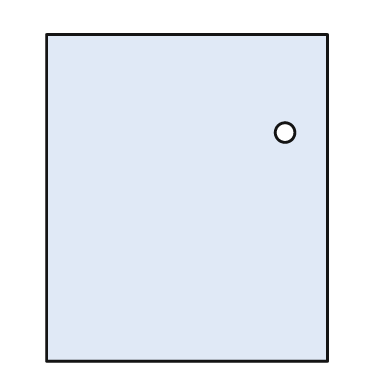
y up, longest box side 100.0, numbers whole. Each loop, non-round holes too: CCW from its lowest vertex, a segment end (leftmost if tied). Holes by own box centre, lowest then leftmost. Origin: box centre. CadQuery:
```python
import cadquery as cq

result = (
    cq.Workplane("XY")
    .moveTo(-43.0, -50.0)
    .lineTo(43.0, -50.0)
    .lineTo(43.0, 50.0)
    .lineTo(-43.0, 50.0)
    .close()
    .moveTo(30.0, 20.0)
    .circle(3.0)
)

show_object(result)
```